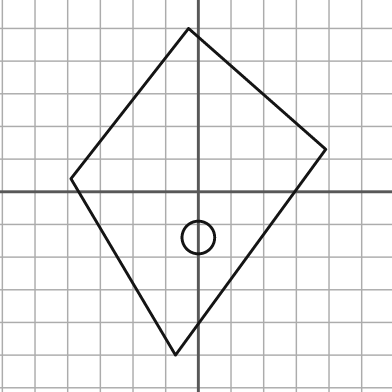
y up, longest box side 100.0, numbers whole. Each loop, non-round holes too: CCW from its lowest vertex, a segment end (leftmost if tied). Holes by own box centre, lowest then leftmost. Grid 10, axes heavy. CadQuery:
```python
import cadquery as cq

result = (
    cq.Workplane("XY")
    .moveTo(-7.0, -50.0)
    .lineTo(39.0, 13.0)
    .lineTo(-3.0, 50.0)
    .lineTo(-39.0, 4.0)
    .close()
    .moveTo(0.0, -14.0)
    .circle(5.0)
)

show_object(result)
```